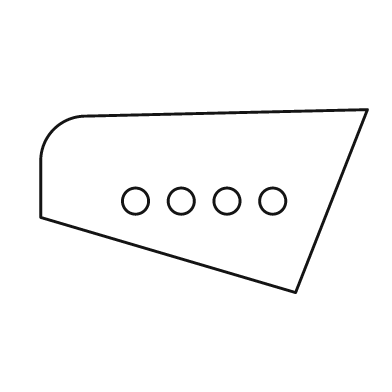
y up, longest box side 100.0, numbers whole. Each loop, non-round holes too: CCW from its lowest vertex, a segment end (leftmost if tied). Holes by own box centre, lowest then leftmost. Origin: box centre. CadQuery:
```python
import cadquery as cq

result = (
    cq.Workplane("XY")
    .moveTo(28.0, -28.0)
    .lineTo(50.0, 28.0)
    .lineTo(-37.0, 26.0)
    .threePointArc((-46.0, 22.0), (-50.0, 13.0))
    .lineTo(-50.0, -5.0)
    .close()
    .moveTo(-21.0, 0.0)
    .circle(4.0)
    .moveTo(-7.0, 0.0)
    .circle(4.0)
    .moveTo(7.0, 0.0)
    .circle(4.0)
    .moveTo(21.0, 0.0)
    .circle(4.0)
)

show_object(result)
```